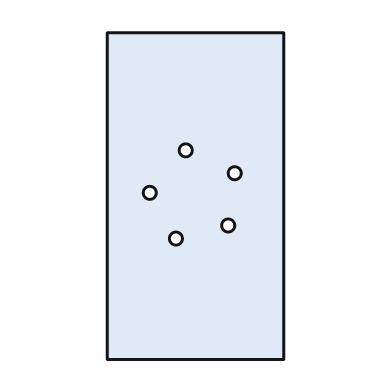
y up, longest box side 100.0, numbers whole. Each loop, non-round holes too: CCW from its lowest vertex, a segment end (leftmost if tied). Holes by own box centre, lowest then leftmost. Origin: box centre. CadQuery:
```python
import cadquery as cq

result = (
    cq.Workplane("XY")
    .moveTo(-27.0, -50.0)
    .lineTo(27.0, -50.0)
    .lineTo(27.0, 50.0)
    .lineTo(-27.0, 50.0)
    .close()
    .moveTo(-6.0, -13.0)
    .circle(2.0)
    .moveTo(10.0, -9.0)
    .circle(2.0)
    .moveTo(-14.0, 1.0)
    .circle(2.0)
    .moveTo(12.0, 7.0)
    .circle(2.0)
    .moveTo(-3.0, 14.0)
    .circle(2.0)
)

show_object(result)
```